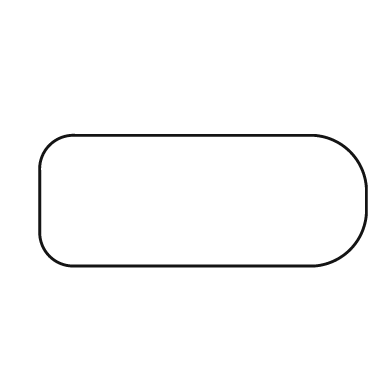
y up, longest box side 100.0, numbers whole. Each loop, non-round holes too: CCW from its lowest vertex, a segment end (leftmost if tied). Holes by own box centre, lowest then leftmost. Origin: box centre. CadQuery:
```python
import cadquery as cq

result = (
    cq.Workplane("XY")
    .moveTo(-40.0, -20.0)
    .lineTo(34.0, -20.0)
    .threePointArc((45.0, -15.0), (50.0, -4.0))
    .lineTo(50.0, 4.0)
    .threePointArc((45.0, 15.0), (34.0, 20.0))
    .lineTo(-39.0, 20.0)
    .threePointArc((-47.0, 17.0), (-50.0, 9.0))
    .lineTo(-50.0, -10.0)
    .threePointArc((-47.0, -17.0), (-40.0, -20.0))
    .close()
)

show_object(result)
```